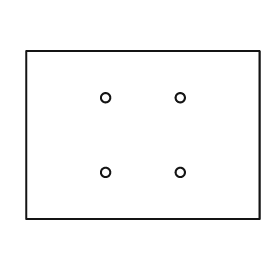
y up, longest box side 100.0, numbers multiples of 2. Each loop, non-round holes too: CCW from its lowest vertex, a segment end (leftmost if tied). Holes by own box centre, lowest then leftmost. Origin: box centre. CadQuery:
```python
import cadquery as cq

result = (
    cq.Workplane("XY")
    .moveTo(-50.0, -36.0)
    .lineTo(50.0, -36.0)
    .lineTo(50.0, 36.0)
    .lineTo(-50.0, 36.0)
    .close()
    .moveTo(-16.0, -16.0)
    .circle(2.0)
    .moveTo(16.0, -16.0)
    .circle(2.0)
    .moveTo(-16.0, 16.0)
    .circle(2.0)
    .moveTo(16.0, 16.0)
    .circle(2.0)
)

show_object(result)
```